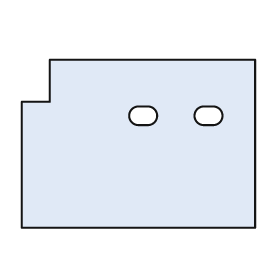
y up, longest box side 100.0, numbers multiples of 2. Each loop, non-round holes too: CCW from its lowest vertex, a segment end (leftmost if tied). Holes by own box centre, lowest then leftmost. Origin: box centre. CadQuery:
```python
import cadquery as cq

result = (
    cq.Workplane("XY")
    .moveTo(-50.0, -36.0)
    .lineTo(50.0, -36.0)
    .lineTo(50.0, 36.0)
    .lineTo(-38.0, 36.0)
    .lineTo(-38.0, 18.0)
    .lineTo(-50.0, 18.0)
    .close()
    .moveTo(0.0, 8.0)
    .lineTo(4.0, 8.0)
    .threePointArc((8.0, 12.0), (4.0, 16.0))
    .lineTo(0.0, 16.0)
    .threePointArc((-4.0, 12.0), (0.0, 8.0))
    .close()
    .moveTo(28.0, 8.0)
    .lineTo(32.0, 8.0)
    .threePointArc((36.0, 12.0), (32.0, 16.0))
    .lineTo(28.0, 16.0)
    .threePointArc((24.0, 12.0), (28.0, 8.0))
    .close()
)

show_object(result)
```